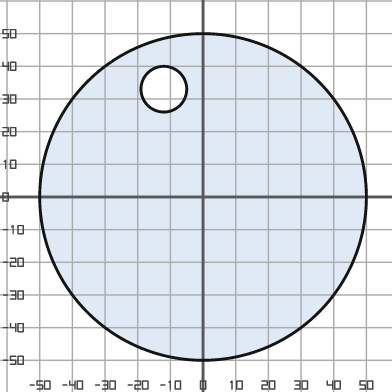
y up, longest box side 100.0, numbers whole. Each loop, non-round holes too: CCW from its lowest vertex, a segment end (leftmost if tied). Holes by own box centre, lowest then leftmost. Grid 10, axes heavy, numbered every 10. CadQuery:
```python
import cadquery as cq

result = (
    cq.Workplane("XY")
    .moveTo(0.0, 0.0)
    .circle(50.0)
    .moveTo(-12.0, 33.0)
    .circle(7.0)
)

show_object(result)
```